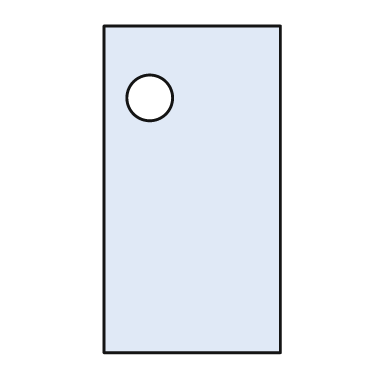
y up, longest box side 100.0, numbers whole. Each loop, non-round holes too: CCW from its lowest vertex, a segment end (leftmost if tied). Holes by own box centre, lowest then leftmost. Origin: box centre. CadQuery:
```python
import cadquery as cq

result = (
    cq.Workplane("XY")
    .moveTo(-27.0, -50.0)
    .lineTo(27.0, -50.0)
    .lineTo(27.0, 50.0)
    .lineTo(-27.0, 50.0)
    .close()
    .moveTo(-13.0, 28.0)
    .circle(7.0)
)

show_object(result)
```